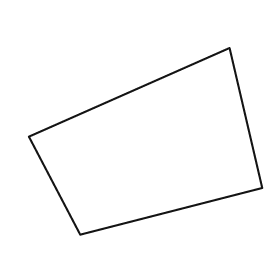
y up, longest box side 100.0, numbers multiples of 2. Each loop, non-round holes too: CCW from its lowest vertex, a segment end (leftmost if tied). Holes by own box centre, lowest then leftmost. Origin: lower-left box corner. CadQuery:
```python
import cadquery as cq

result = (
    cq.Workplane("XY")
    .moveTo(22.0, 0.0)
    .lineTo(100.0, 20.0)
    .lineTo(86.0, 80.0)
    .lineTo(0.0, 42.0)
    .close()
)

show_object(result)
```